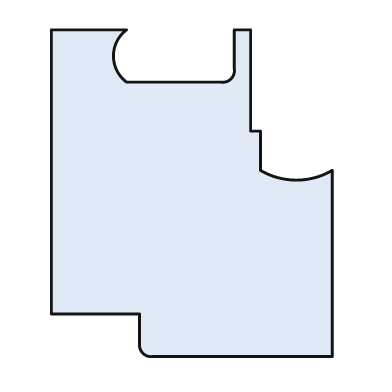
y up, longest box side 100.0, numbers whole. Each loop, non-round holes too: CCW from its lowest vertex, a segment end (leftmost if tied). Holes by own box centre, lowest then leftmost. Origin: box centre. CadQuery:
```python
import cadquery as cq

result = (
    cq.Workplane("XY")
    .moveTo(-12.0, -50.0)
    .lineTo(43.0, -50.0)
    .lineTo(43.0, 7.0)
    .threePointArc((32.0, 4.0), (21.0, 7.0))
    .lineTo(21.0, 19.0)
    .lineTo(18.0, 19.0)
    .lineTo(18.0, 50.0)
    .lineTo(13.0, 50.0)
    .lineTo(13.0, 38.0)
    .threePointArc((12.0, 35.0), (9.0, 34.0))
    .lineTo(-20.0, 34.0)
    .threePointArc((-24.0, 42.0), (-20.0, 50.0))
    .lineTo(-43.0, 50.0)
    .lineTo(-43.0, -37.0)
    .lineTo(-16.0, -37.0)
    .lineTo(-16.0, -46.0)
    .threePointArc((-15.0, -49.0), (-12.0, -50.0))
    .close()
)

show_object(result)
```